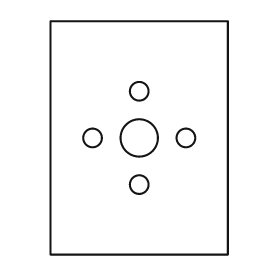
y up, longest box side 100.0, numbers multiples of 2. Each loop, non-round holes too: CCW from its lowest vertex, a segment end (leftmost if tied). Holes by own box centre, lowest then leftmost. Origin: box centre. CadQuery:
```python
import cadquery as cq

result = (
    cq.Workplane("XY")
    .moveTo(-38.0, -50.0)
    .lineTo(38.0, -50.0)
    .lineTo(38.0, 50.0)
    .lineTo(-38.0, 50.0)
    .close()
    .moveTo(0.0, -20.0)
    .circle(4.0)
    .moveTo(-20.0, 0.0)
    .circle(4.0)
    .moveTo(0.0, 0.0)
    .circle(8.0)
    .moveTo(20.0, 0.0)
    .circle(4.0)
    .moveTo(0.0, 20.0)
    .circle(4.0)
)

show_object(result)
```